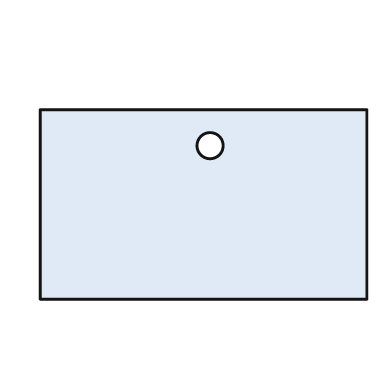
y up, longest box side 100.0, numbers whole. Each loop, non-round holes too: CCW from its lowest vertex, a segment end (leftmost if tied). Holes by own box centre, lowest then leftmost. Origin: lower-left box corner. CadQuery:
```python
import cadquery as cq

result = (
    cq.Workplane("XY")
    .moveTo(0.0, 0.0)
    .lineTo(100.0, 0.0)
    .lineTo(100.0, 58.0)
    .lineTo(0.0, 58.0)
    .close()
    .moveTo(52.0, 47.0)
    .circle(4.0)
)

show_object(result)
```